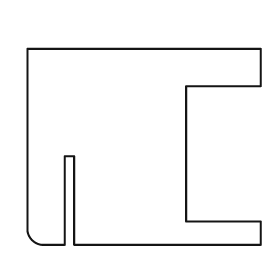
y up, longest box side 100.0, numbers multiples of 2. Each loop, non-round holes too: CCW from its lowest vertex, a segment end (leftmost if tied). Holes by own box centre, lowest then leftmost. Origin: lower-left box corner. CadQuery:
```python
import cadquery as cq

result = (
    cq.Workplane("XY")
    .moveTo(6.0, 0.0)
    .lineTo(16.0, 0.0)
    .lineTo(16.0, 38.0)
    .lineTo(20.0, 38.0)
    .lineTo(20.0, 0.0)
    .lineTo(100.0, 0.0)
    .lineTo(100.0, 10.0)
    .lineTo(68.0, 10.0)
    .lineTo(68.0, 68.0)
    .lineTo(100.0, 68.0)
    .lineTo(100.0, 84.0)
    .lineTo(0.0, 84.0)
    .lineTo(0.0, 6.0)
    .threePointArc((2.0, 2.0), (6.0, 0.0))
    .close()
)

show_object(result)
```